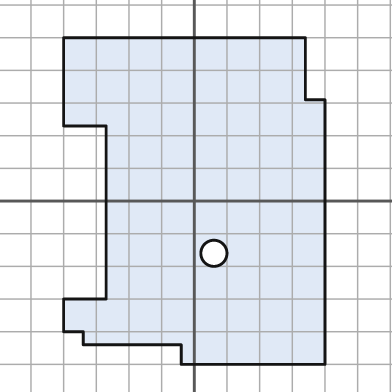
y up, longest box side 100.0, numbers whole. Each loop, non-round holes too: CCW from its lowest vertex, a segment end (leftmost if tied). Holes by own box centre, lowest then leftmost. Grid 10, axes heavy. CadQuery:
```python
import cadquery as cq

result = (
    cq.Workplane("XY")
    .moveTo(-4.0, -50.0)
    .lineTo(40.0, -50.0)
    .lineTo(40.0, 31.0)
    .lineTo(34.0, 31.0)
    .lineTo(34.0, 50.0)
    .lineTo(-40.0, 50.0)
    .lineTo(-40.0, 23.0)
    .lineTo(-27.0, 23.0)
    .lineTo(-27.0, -30.0)
    .lineTo(-40.0, -30.0)
    .lineTo(-40.0, -40.0)
    .lineTo(-34.0, -40.0)
    .lineTo(-34.0, -44.0)
    .lineTo(-4.0, -44.0)
    .close()
    .moveTo(6.0, -16.0)
    .circle(4.0)
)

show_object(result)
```